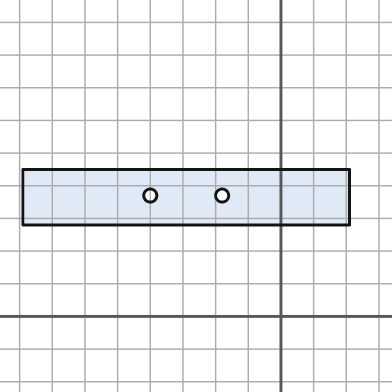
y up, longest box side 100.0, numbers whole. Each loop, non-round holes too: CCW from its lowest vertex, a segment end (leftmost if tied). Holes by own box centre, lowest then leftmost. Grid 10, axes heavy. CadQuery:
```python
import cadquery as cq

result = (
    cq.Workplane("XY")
    .moveTo(-79.0, 28.0)
    .lineTo(21.0, 28.0)
    .lineTo(21.0, 45.0)
    .lineTo(-79.0, 45.0)
    .close()
    .moveTo(-40.0, 37.0)
    .circle(2.0)
    .moveTo(-18.0, 37.0)
    .circle(2.0)
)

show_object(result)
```